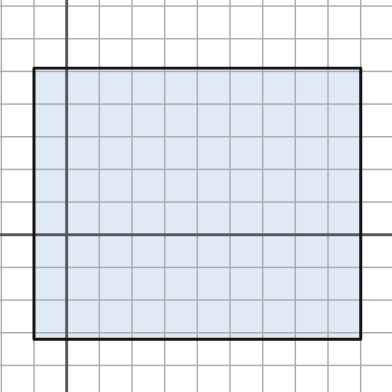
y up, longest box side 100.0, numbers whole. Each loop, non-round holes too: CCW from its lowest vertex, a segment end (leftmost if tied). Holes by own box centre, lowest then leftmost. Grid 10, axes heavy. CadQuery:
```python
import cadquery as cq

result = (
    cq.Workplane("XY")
    .moveTo(-10.0, -32.0)
    .lineTo(90.0, -32.0)
    .lineTo(90.0, 51.0)
    .lineTo(-10.0, 51.0)
    .close()
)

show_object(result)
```